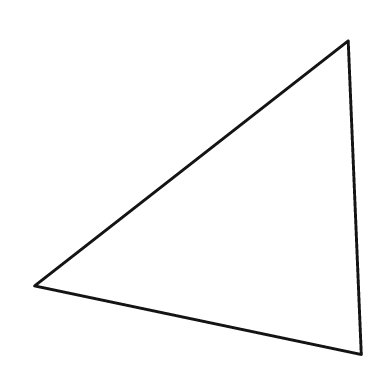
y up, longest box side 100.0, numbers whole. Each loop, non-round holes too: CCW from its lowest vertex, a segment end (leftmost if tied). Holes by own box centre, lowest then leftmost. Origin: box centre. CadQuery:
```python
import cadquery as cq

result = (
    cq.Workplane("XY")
    .moveTo(50.0, -48.0)
    .lineTo(46.0, 48.0)
    .lineTo(-50.0, -27.0)
    .close()
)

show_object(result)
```